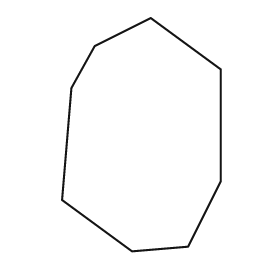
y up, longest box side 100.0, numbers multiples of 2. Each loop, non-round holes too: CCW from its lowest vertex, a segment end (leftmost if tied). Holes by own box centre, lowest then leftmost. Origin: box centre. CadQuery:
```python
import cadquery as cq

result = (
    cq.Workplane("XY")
    .moveTo(-4.0, -50.0)
    .lineTo(20.0, -48.0)
    .lineTo(34.0, -20.0)
    .lineTo(34.0, 28.0)
    .lineTo(4.0, 50.0)
    .lineTo(-20.0, 38.0)
    .lineTo(-30.0, 20.0)
    .lineTo(-34.0, -28.0)
    .close()
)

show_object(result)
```